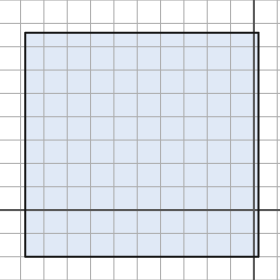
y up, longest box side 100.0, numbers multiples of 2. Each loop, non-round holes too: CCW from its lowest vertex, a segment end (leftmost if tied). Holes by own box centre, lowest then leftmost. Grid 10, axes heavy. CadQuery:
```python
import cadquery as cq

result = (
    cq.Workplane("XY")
    .moveTo(-98.0, -20.0)
    .lineTo(2.0, -20.0)
    .lineTo(2.0, 76.0)
    .lineTo(-98.0, 76.0)
    .close()
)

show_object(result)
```